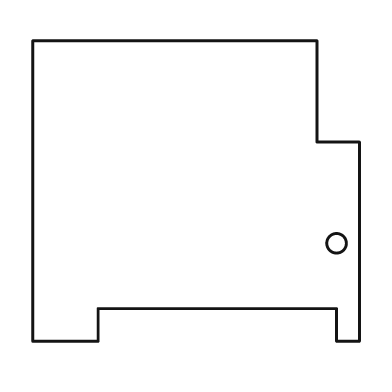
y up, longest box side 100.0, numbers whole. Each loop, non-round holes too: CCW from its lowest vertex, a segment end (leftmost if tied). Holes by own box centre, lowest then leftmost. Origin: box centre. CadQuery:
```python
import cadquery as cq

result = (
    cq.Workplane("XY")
    .moveTo(-50.0, -46.0)
    .lineTo(-30.0, -46.0)
    .lineTo(-30.0, -36.0)
    .lineTo(43.0, -36.0)
    .lineTo(43.0, -46.0)
    .lineTo(50.0, -46.0)
    .lineTo(50.0, 15.0)
    .lineTo(37.0, 15.0)
    .lineTo(37.0, 46.0)
    .lineTo(-50.0, 46.0)
    .close()
    .moveTo(43.0, -16.0)
    .circle(3.0)
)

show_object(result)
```